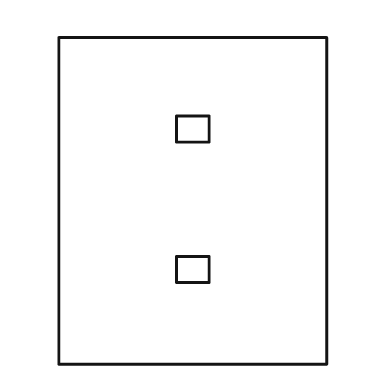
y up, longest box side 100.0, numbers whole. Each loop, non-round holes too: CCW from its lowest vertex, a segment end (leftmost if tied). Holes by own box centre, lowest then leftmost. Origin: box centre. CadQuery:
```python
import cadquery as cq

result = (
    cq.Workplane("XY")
    .moveTo(-41.0, -50.0)
    .lineTo(41.0, -50.0)
    .lineTo(41.0, 50.0)
    .lineTo(-41.0, 50.0)
    .close()
    .moveTo(-5.0, -25.0)
    .lineTo(5.0, -25.0)
    .lineTo(5.0, -17.0)
    .lineTo(-5.0, -17.0)
    .close()
    .moveTo(-5.0, 18.0)
    .lineTo(5.0, 18.0)
    .lineTo(5.0, 26.0)
    .lineTo(-5.0, 26.0)
    .close()
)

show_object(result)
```